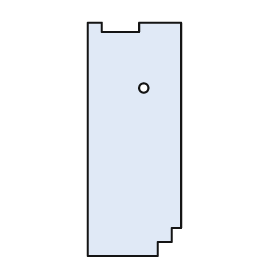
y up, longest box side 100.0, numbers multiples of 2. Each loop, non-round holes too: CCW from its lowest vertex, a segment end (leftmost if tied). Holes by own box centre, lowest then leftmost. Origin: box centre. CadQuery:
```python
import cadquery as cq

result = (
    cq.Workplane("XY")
    .moveTo(-20.0, -50.0)
    .lineTo(10.0, -50.0)
    .lineTo(10.0, -44.0)
    .lineTo(16.0, -44.0)
    .lineTo(16.0, -38.0)
    .lineTo(20.0, -38.0)
    .lineTo(20.0, 50.0)
    .lineTo(2.0, 50.0)
    .lineTo(2.0, 46.0)
    .lineTo(-14.0, 46.0)
    .lineTo(-14.0, 50.0)
    .lineTo(-20.0, 50.0)
    .close()
    .moveTo(4.0, 22.0)
    .circle(2.0)
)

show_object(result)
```